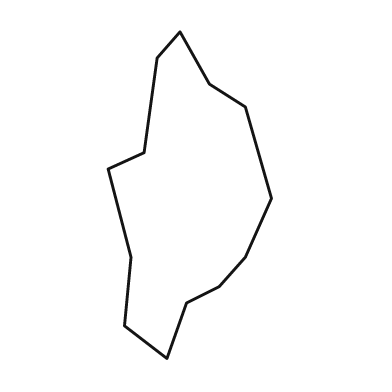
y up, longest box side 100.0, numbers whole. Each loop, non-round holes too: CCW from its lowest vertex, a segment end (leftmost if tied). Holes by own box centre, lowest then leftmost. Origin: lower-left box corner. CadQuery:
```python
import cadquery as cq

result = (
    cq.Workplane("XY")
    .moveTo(18.0, 0.0)
    .lineTo(24.0, 17.0)
    .lineTo(34.0, 22.0)
    .lineTo(42.0, 31.0)
    .lineTo(50.0, 49.0)
    .lineTo(42.0, 77.0)
    .lineTo(31.0, 84.0)
    .lineTo(22.0, 100.0)
    .lineTo(15.0, 92.0)
    .lineTo(11.0, 63.0)
    .lineTo(0.0, 58.0)
    .lineTo(7.0, 31.0)
    .lineTo(5.0, 10.0)
    .close()
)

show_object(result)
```